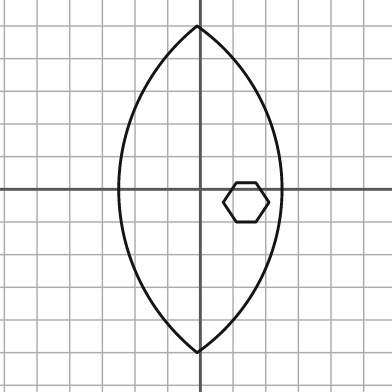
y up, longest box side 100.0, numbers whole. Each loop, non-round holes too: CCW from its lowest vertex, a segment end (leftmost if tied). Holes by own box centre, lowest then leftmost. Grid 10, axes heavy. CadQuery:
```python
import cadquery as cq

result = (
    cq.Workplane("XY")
    .moveTo(-1.0, -50.0)
    .threePointArc((25.0, 0.0), (-1.0, 50.0))
    .threePointArc((-25.0, 0.0), (-1.0, -50.0))
    .close()
    .moveTo(11.0, -10.0)
    .lineTo(17.0, -10.0)
    .lineTo(21.0, -4.0)
    .lineTo(17.0, 2.0)
    .lineTo(11.0, 2.0)
    .lineTo(7.0, -4.0)
    .close()
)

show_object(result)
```